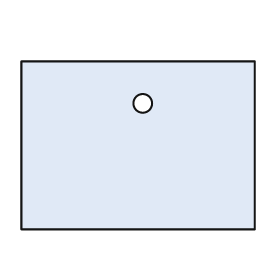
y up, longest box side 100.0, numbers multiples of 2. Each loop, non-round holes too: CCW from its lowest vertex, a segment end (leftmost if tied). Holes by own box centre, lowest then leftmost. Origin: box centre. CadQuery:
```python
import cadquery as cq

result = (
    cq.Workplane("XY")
    .moveTo(-50.0, -36.0)
    .lineTo(50.0, -36.0)
    .lineTo(50.0, 36.0)
    .lineTo(-50.0, 36.0)
    .close()
    .moveTo(2.0, 18.0)
    .circle(4.0)
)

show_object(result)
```